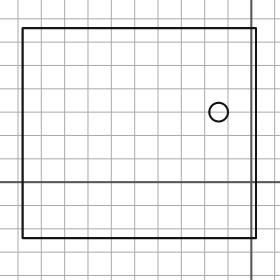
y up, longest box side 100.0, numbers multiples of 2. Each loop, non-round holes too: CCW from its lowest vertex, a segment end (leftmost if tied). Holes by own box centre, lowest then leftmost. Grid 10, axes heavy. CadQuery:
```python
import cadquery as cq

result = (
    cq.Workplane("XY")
    .moveTo(-98.0, -24.0)
    .lineTo(2.0, -24.0)
    .lineTo(2.0, 66.0)
    .lineTo(-98.0, 66.0)
    .close()
    .moveTo(-14.0, 30.0)
    .circle(4.0)
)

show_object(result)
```